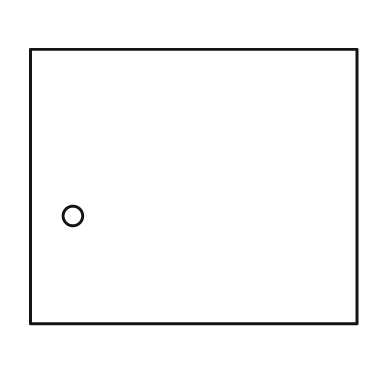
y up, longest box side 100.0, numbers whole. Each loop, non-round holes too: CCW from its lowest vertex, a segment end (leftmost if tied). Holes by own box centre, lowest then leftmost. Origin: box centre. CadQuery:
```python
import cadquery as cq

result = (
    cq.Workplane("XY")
    .moveTo(-50.0, -42.0)
    .lineTo(50.0, -42.0)
    .lineTo(50.0, 42.0)
    .lineTo(-50.0, 42.0)
    .close()
    .moveTo(-37.0, -9.0)
    .circle(3.0)
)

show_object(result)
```